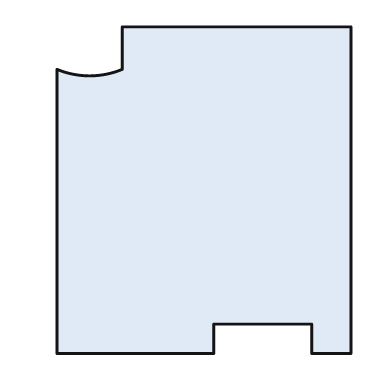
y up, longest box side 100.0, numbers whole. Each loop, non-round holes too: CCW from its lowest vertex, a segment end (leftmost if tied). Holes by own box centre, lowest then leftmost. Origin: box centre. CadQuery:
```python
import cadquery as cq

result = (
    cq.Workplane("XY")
    .moveTo(-45.0, -50.0)
    .lineTo(3.0, -50.0)
    .lineTo(3.0, -41.0)
    .lineTo(33.0, -41.0)
    .lineTo(33.0, -50.0)
    .lineTo(45.0, -50.0)
    .lineTo(45.0, 50.0)
    .lineTo(-25.0, 50.0)
    .lineTo(-25.0, 37.0)
    .threePointArc((-35.0, 35.0), (-45.0, 37.0))
    .close()
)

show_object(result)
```